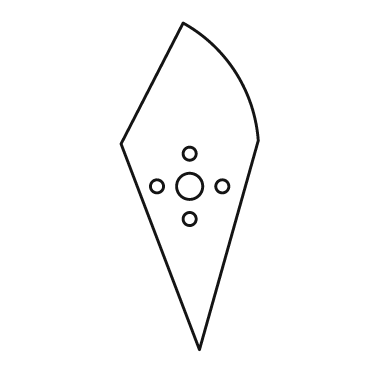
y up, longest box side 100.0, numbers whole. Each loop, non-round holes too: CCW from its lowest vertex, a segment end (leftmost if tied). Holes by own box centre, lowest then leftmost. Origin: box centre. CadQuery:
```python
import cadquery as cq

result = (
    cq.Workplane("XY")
    .moveTo(3.0, -50.0)
    .lineTo(21.0, 14.0)
    .threePointArc((14.0, 35.0), (-2.0, 50.0))
    .lineTo(-21.0, 13.0)
    .close()
    .moveTo(0.0, -10.0)
    .circle(2.0)
    .moveTo(-10.0, 0.0)
    .circle(2.0)
    .moveTo(0.0, 0.0)
    .circle(4.0)
    .moveTo(10.0, 0.0)
    .circle(2.0)
    .moveTo(0.0, 10.0)
    .circle(2.0)
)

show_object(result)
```